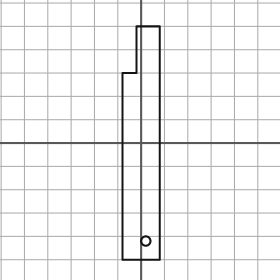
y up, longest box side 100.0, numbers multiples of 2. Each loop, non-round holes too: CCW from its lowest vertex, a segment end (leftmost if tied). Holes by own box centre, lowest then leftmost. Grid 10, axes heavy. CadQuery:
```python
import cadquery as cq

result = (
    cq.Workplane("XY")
    .moveTo(-8.0, -50.0)
    .lineTo(8.0, -50.0)
    .lineTo(8.0, 50.0)
    .lineTo(-2.0, 50.0)
    .lineTo(-2.0, 30.0)
    .lineTo(-8.0, 30.0)
    .close()
    .moveTo(2.0, -42.0)
    .circle(2.0)
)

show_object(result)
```